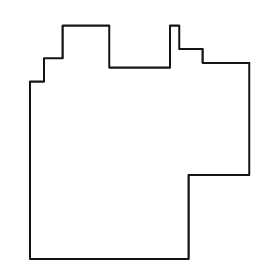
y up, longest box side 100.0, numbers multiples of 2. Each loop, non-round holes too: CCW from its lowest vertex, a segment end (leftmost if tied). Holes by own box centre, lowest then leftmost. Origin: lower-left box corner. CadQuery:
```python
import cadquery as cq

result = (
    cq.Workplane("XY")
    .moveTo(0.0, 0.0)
    .lineTo(68.0, 0.0)
    .lineTo(68.0, 36.0)
    .lineTo(94.0, 36.0)
    .lineTo(94.0, 84.0)
    .lineTo(74.0, 84.0)
    .lineTo(74.0, 90.0)
    .lineTo(64.0, 90.0)
    .lineTo(64.0, 100.0)
    .lineTo(60.0, 100.0)
    .lineTo(60.0, 82.0)
    .lineTo(34.0, 82.0)
    .lineTo(34.0, 100.0)
    .lineTo(14.0, 100.0)
    .lineTo(14.0, 86.0)
    .lineTo(6.0, 86.0)
    .lineTo(6.0, 76.0)
    .lineTo(0.0, 76.0)
    .close()
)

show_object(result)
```